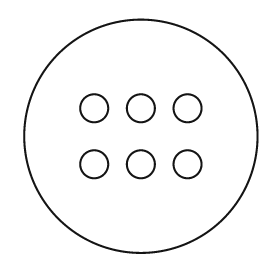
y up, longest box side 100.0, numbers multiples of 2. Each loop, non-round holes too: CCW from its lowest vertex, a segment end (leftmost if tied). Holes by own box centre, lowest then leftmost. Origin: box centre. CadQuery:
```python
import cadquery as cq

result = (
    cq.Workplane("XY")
    .moveTo(0.0, 0.0)
    .circle(50.0)
    .moveTo(-20.0, -12.0)
    .circle(6.0)
    .moveTo(0.0, -12.0)
    .circle(6.0)
    .moveTo(20.0, -12.0)
    .circle(6.0)
    .moveTo(-20.0, 12.0)
    .circle(6.0)
    .moveTo(0.0, 12.0)
    .circle(6.0)
    .moveTo(20.0, 12.0)
    .circle(6.0)
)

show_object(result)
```